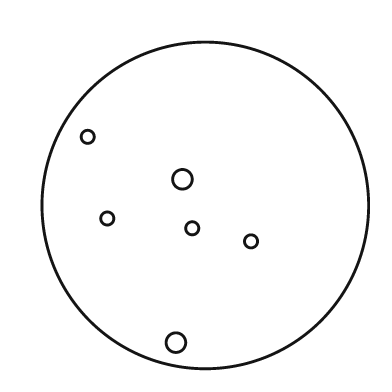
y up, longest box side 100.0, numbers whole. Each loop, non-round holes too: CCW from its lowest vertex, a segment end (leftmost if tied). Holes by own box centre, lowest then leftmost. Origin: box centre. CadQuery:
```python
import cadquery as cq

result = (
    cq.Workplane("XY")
    .moveTo(0.0, 0.0)
    .circle(50.0)
    .moveTo(-9.0, -42.0)
    .circle(3.0)
    .moveTo(14.0, -11.0)
    .circle(2.0)
    .moveTo(-4.0, -7.0)
    .circle(2.0)
    .moveTo(-30.0, -4.0)
    .circle(2.0)
    .moveTo(-7.0, 8.0)
    .circle(3.0)
    .moveTo(-36.0, 21.0)
    .circle(2.0)
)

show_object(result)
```